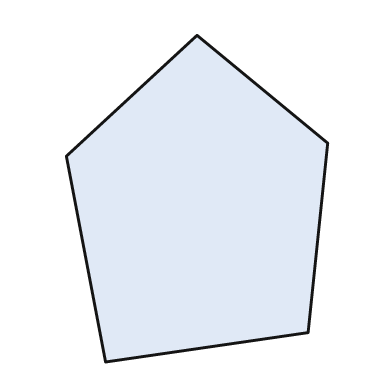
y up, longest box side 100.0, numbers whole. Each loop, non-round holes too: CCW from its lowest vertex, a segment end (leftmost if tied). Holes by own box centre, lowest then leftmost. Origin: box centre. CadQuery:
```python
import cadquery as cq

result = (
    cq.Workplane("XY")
    .moveTo(-28.0, -50.0)
    .lineTo(34.0, -41.0)
    .lineTo(40.0, 17.0)
    .lineTo(0.0, 50.0)
    .lineTo(-40.0, 13.0)
    .close()
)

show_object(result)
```